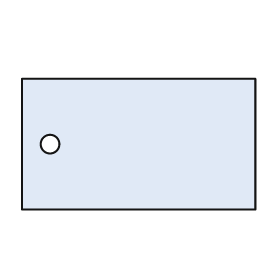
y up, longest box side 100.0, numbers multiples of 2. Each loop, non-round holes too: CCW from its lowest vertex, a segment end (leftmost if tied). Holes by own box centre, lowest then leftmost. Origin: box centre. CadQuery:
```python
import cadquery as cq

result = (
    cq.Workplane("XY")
    .moveTo(-50.0, -28.0)
    .lineTo(50.0, -28.0)
    .lineTo(50.0, 28.0)
    .lineTo(-50.0, 28.0)
    .close()
    .moveTo(-38.0, 0.0)
    .circle(4.0)
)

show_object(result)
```